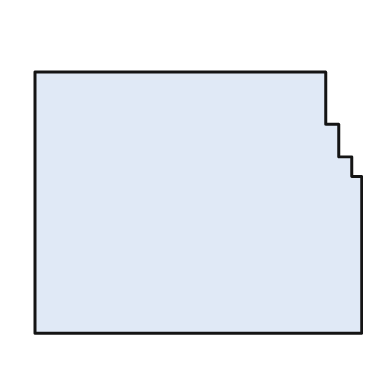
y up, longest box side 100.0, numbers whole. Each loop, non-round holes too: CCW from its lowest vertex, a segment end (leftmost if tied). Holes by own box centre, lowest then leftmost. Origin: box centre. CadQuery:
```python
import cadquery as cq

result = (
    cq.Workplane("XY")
    .moveTo(-50.0, -40.0)
    .lineTo(50.0, -40.0)
    .lineTo(50.0, 8.0)
    .lineTo(47.0, 8.0)
    .lineTo(47.0, 14.0)
    .lineTo(43.0, 14.0)
    .lineTo(43.0, 24.0)
    .lineTo(39.0, 24.0)
    .lineTo(39.0, 40.0)
    .lineTo(-50.0, 40.0)
    .close()
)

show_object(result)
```